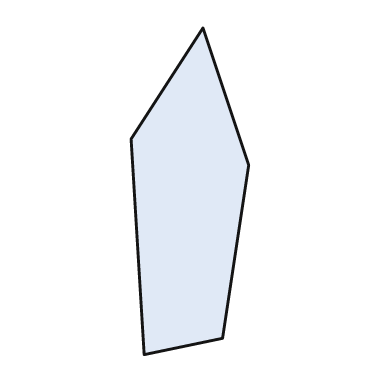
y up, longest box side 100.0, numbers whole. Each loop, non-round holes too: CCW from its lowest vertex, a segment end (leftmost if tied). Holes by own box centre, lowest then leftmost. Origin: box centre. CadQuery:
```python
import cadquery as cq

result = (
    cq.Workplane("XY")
    .moveTo(-14.0, -50.0)
    .lineTo(10.0, -45.0)
    .lineTo(18.0, 8.0)
    .lineTo(4.0, 50.0)
    .lineTo(-18.0, 16.0)
    .close()
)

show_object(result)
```